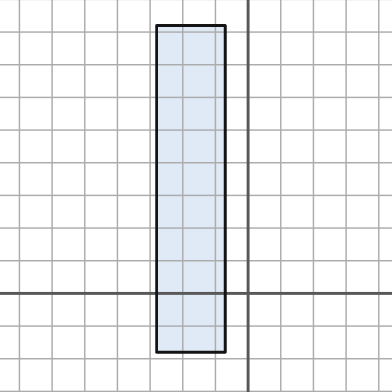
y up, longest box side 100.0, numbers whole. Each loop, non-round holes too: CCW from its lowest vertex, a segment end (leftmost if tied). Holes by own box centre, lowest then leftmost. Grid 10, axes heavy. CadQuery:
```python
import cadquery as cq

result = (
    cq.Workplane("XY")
    .moveTo(-28.0, -18.0)
    .lineTo(-7.0, -18.0)
    .lineTo(-7.0, 82.0)
    .lineTo(-28.0, 82.0)
    .close()
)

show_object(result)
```